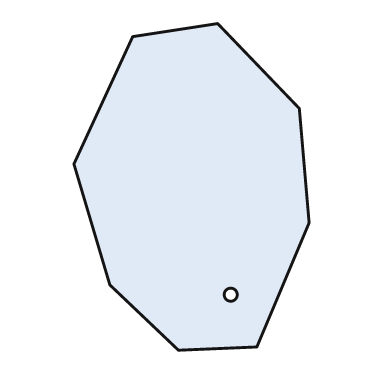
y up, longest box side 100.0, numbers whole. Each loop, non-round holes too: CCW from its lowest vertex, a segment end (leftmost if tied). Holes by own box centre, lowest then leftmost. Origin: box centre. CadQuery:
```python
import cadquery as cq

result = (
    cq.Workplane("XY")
    .moveTo(-4.0, -50.0)
    .lineTo(20.0, -49.0)
    .lineTo(36.0, -11.0)
    .lineTo(33.0, 24.0)
    .lineTo(8.0, 50.0)
    .lineTo(-18.0, 46.0)
    .lineTo(-36.0, 7.0)
    .lineTo(-25.0, -30.0)
    .close()
    .moveTo(12.0, -33.0)
    .circle(2.0)
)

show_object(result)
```